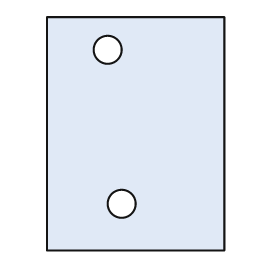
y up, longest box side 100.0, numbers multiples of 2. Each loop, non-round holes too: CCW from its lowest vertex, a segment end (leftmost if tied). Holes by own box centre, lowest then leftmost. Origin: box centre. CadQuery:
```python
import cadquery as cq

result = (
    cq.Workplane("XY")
    .moveTo(-38.0, -50.0)
    .lineTo(38.0, -50.0)
    .lineTo(38.0, 50.0)
    .lineTo(-38.0, 50.0)
    .close()
    .moveTo(-6.0, -30.0)
    .circle(6.0)
    .moveTo(-12.0, 36.0)
    .circle(6.0)
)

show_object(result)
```